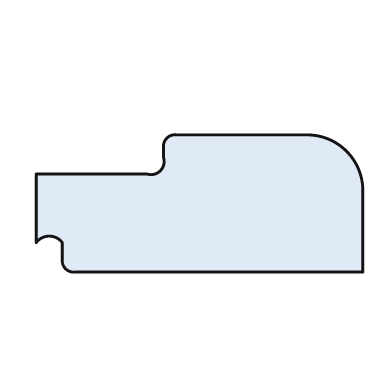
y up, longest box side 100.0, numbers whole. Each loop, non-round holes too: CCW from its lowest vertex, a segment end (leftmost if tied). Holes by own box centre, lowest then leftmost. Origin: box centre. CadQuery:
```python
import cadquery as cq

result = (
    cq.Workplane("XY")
    .moveTo(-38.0, -21.0)
    .lineTo(50.0, -21.0)
    .lineTo(50.0, 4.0)
    .threePointArc((45.0, 16.0), (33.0, 21.0))
    .lineTo(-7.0, 21.0)
    .threePointArc((-10.0, 20.0), (-11.0, 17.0))
    .lineTo(-11.0, 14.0)
    .threePointArc((-12.0, 10.0), (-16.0, 9.0))
    .lineTo(-50.0, 9.0)
    .lineTo(-50.0, -12.0)
    .threePointArc((-46.0, -10.0), (-42.0, -12.0))
    .lineTo(-42.0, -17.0)
    .threePointArc((-41.0, -20.0), (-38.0, -21.0))
    .close()
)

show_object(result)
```